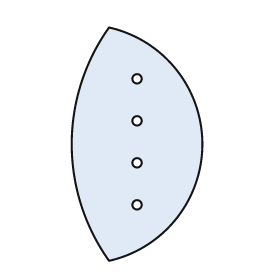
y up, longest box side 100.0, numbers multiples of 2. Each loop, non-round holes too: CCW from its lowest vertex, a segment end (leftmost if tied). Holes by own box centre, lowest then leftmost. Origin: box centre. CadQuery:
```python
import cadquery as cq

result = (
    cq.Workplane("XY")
    .moveTo(-12.0, -50.0)
    .threePointArc((28.0, 0.0), (-12.0, 50.0))
    .threePointArc((-28.0, 0.0), (-12.0, -50.0))
    .close()
    .moveTo(0.0, -26.0)
    .circle(2.0)
    .moveTo(0.0, -8.0)
    .circle(2.0)
    .moveTo(0.0, 10.0)
    .circle(2.0)
    .moveTo(0.0, 28.0)
    .circle(2.0)
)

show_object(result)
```